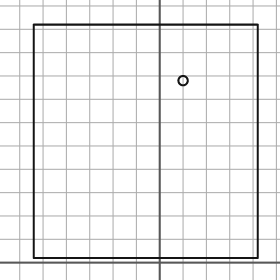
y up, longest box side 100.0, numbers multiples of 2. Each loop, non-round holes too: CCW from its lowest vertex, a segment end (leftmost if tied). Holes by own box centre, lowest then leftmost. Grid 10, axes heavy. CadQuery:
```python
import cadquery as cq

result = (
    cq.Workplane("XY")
    .moveTo(-54.0, 2.0)
    .lineTo(42.0, 2.0)
    .lineTo(42.0, 102.0)
    .lineTo(-54.0, 102.0)
    .close()
    .moveTo(10.0, 78.0)
    .circle(2.0)
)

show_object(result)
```